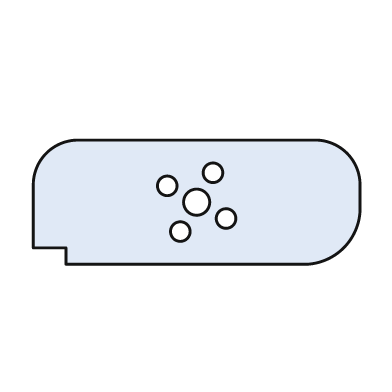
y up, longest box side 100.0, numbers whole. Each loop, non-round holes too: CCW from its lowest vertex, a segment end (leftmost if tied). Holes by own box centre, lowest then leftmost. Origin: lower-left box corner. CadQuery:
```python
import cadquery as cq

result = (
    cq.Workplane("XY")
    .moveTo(10.0, 0.0)
    .lineTo(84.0, 0.0)
    .threePointArc((95.0, 5.0), (100.0, 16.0))
    .lineTo(100.0, 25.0)
    .threePointArc((96.0, 34.0), (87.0, 38.0))
    .lineTo(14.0, 38.0)
    .threePointArc((4.0, 34.0), (0.0, 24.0))
    .lineTo(0.0, 5.0)
    .lineTo(10.0, 5.0)
    .close()
    .moveTo(45.0, 10.0)
    .circle(3.0)
    .moveTo(59.0, 14.0)
    .circle(3.0)
    .moveTo(50.0, 19.0)
    .circle(4.0)
    .moveTo(41.0, 24.0)
    .circle(3.0)
    .moveTo(55.0, 28.0)
    .circle(3.0)
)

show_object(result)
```